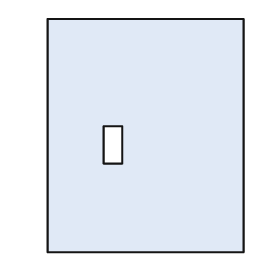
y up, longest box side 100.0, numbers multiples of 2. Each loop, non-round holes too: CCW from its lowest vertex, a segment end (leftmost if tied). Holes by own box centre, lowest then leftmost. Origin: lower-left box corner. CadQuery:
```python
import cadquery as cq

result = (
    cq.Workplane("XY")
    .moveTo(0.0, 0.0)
    .lineTo(84.0, 0.0)
    .lineTo(84.0, 100.0)
    .lineTo(0.0, 100.0)
    .close()
    .moveTo(24.0, 38.0)
    .lineTo(32.0, 38.0)
    .lineTo(32.0, 54.0)
    .lineTo(24.0, 54.0)
    .close()
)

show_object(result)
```